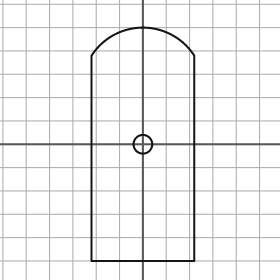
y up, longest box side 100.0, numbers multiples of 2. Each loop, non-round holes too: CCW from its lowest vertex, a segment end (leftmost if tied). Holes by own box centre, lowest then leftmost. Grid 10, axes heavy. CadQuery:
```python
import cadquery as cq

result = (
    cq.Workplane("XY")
    .moveTo(-22.0, -50.0)
    .lineTo(22.0, -50.0)
    .lineTo(22.0, 38.0)
    .threePointArc((0.0, 50.0), (-22.0, 38.0))
    .close()
    .moveTo(0.0, 0.0)
    .circle(4.0)
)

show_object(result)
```